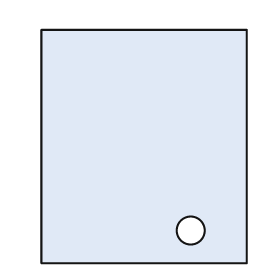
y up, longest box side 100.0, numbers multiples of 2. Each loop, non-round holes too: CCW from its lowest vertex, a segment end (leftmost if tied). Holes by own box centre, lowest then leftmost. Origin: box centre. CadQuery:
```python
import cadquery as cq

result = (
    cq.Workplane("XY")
    .moveTo(-44.0, -50.0)
    .lineTo(44.0, -50.0)
    .lineTo(44.0, 50.0)
    .lineTo(-44.0, 50.0)
    .close()
    .moveTo(20.0, -36.0)
    .circle(6.0)
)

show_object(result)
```